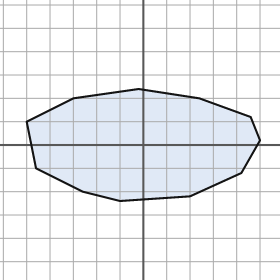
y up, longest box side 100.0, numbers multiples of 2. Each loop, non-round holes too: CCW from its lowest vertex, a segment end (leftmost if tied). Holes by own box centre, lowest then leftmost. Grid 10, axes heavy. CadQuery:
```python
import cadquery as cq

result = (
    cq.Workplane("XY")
    .moveTo(-10.0, -24.0)
    .lineTo(20.0, -22.0)
    .lineTo(42.0, -12.0)
    .lineTo(50.0, 2.0)
    .lineTo(46.0, 12.0)
    .lineTo(24.0, 20.0)
    .lineTo(-2.0, 24.0)
    .lineTo(-30.0, 20.0)
    .lineTo(-50.0, 10.0)
    .lineTo(-46.0, -10.0)
    .lineTo(-26.0, -20.0)
    .close()
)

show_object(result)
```